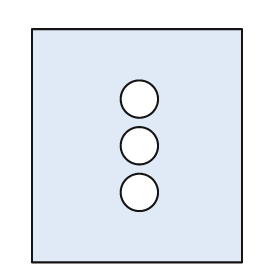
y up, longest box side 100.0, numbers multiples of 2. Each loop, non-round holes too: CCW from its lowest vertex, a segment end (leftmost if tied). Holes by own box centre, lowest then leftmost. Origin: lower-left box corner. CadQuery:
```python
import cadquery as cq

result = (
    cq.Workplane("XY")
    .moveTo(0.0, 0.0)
    .lineTo(90.0, 0.0)
    .lineTo(90.0, 100.0)
    .lineTo(0.0, 100.0)
    .close()
    .moveTo(46.0, 30.0)
    .circle(8.0)
    .moveTo(46.0, 50.0)
    .circle(8.0)
    .moveTo(46.0, 70.0)
    .circle(8.0)
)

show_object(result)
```